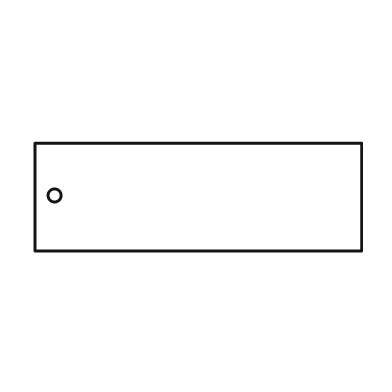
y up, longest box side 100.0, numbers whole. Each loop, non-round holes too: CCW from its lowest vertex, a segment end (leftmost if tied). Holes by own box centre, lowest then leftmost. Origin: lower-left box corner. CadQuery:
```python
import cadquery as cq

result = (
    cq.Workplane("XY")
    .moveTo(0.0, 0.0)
    .lineTo(100.0, 0.0)
    .lineTo(100.0, 33.0)
    .lineTo(0.0, 33.0)
    .close()
    .moveTo(6.0, 17.0)
    .circle(2.0)
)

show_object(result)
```